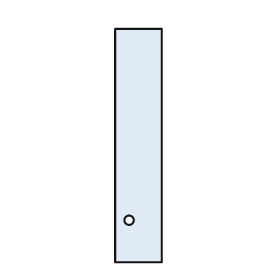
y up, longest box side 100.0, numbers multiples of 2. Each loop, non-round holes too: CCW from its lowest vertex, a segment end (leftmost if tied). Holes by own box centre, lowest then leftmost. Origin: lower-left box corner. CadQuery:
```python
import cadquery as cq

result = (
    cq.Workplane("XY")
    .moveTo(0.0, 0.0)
    .lineTo(20.0, 0.0)
    .lineTo(20.0, 100.0)
    .lineTo(0.0, 100.0)
    .close()
    .moveTo(6.0, 18.0)
    .circle(2.0)
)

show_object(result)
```